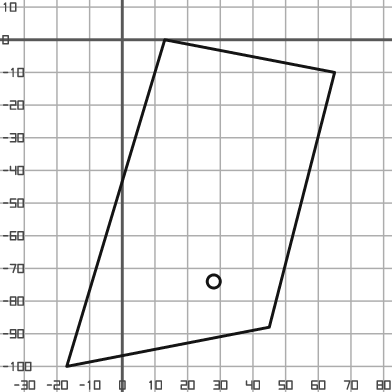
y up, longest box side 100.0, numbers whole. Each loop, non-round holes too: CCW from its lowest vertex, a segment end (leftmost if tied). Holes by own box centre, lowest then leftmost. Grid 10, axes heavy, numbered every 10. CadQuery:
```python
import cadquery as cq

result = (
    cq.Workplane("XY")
    .moveTo(-17.0, -100.0)
    .lineTo(45.0, -88.0)
    .lineTo(65.0, -10.0)
    .lineTo(13.0, 0.0)
    .close()
    .moveTo(28.0, -74.0)
    .circle(2.0)
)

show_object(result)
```